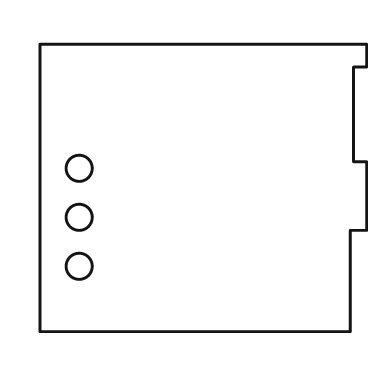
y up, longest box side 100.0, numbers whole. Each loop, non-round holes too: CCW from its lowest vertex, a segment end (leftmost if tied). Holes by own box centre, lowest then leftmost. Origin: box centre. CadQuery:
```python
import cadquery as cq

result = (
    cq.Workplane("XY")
    .moveTo(-50.0, -44.0)
    .lineTo(45.0, -44.0)
    .lineTo(45.0, -13.0)
    .lineTo(50.0, -13.0)
    .lineTo(50.0, 8.0)
    .lineTo(46.0, 8.0)
    .lineTo(46.0, 37.0)
    .lineTo(50.0, 37.0)
    .lineTo(50.0, 44.0)
    .lineTo(-50.0, 44.0)
    .close()
    .moveTo(-38.0, -24.0)
    .circle(4.0)
    .moveTo(-38.0, -9.0)
    .circle(4.0)
    .moveTo(-38.0, 6.0)
    .circle(4.0)
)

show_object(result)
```